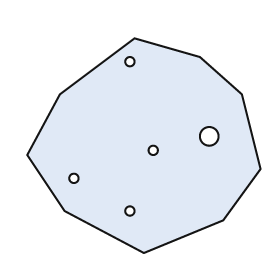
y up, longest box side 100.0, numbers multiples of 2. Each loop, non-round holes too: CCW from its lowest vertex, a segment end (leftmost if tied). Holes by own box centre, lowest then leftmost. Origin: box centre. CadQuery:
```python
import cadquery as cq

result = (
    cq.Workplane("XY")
    .moveTo(0.0, -46.0)
    .lineTo(34.0, -32.0)
    .lineTo(50.0, -10.0)
    .lineTo(42.0, 22.0)
    .lineTo(24.0, 38.0)
    .lineTo(-4.0, 46.0)
    .lineTo(-36.0, 22.0)
    .lineTo(-50.0, -4.0)
    .lineTo(-34.0, -28.0)
    .close()
    .moveTo(-6.0, -28.0)
    .circle(2.0)
    .moveTo(-30.0, -14.0)
    .circle(2.0)
    .moveTo(4.0, -2.0)
    .circle(2.0)
    .moveTo(28.0, 4.0)
    .circle(4.0)
    .moveTo(-6.0, 36.0)
    .circle(2.0)
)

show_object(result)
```